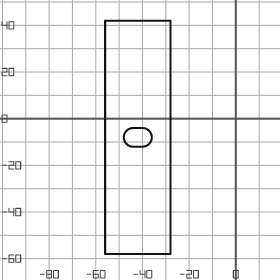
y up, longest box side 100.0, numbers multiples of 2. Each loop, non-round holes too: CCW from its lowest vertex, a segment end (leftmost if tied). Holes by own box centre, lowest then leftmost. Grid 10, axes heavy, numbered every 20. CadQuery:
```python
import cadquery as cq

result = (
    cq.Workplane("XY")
    .moveTo(-56.0, -58.0)
    .lineTo(-28.0, -58.0)
    .lineTo(-28.0, 42.0)
    .lineTo(-56.0, 42.0)
    .close()
    .moveTo(-44.0, -12.0)
    .lineTo(-40.0, -12.0)
    .threePointArc((-36.0, -8.0), (-40.0, -4.0))
    .lineTo(-44.0, -4.0)
    .threePointArc((-48.0, -8.0), (-44.0, -12.0))
    .close()
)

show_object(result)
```